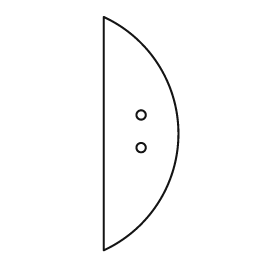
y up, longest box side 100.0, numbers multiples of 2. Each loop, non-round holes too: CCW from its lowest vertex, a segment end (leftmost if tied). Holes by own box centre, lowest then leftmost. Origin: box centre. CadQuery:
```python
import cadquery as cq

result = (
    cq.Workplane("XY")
    .moveTo(-16.0, -50.0)
    .threePointArc((16.0, 0.0), (-16.0, 50.0))
    .close()
    .moveTo(0.0, -6.0)
    .circle(2.0)
    .moveTo(0.0, 8.0)
    .circle(2.0)
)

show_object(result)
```